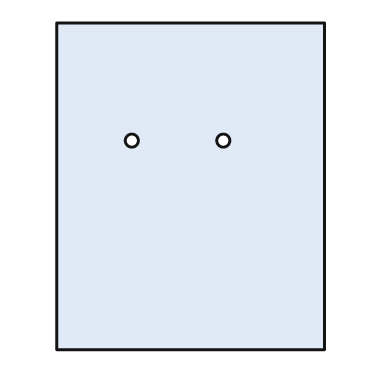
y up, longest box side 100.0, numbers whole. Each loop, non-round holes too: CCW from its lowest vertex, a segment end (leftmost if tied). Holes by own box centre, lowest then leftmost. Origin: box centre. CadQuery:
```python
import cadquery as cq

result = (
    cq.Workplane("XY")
    .moveTo(-41.0, -50.0)
    .lineTo(41.0, -50.0)
    .lineTo(41.0, 50.0)
    .lineTo(-41.0, 50.0)
    .close()
    .moveTo(-18.0, 14.0)
    .circle(2.0)
    .moveTo(10.0, 14.0)
    .circle(2.0)
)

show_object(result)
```